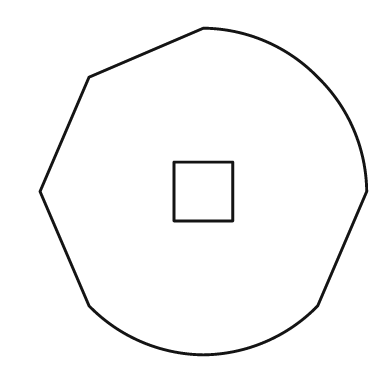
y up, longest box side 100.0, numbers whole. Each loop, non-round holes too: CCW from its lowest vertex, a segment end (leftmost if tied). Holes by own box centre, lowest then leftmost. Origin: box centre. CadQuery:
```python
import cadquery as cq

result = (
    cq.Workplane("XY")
    .moveTo(0.0, -50.0)
    .threePointArc((19.0, -46.0), (35.0, -35.0))
    .lineTo(50.0, 0.0)
    .threePointArc((46.0, 19.0), (35.0, 35.0))
    .threePointArc((19.0, 46.0), (0.0, 50.0))
    .lineTo(-35.0, 35.0)
    .lineTo(-50.0, 0.0)
    .lineTo(-35.0, -35.0)
    .threePointArc((-19.0, -46.0), (0.0, -50.0))
    .close()
    .moveTo(-9.0, -9.0)
    .lineTo(9.0, -9.0)
    .lineTo(9.0, 9.0)
    .lineTo(-9.0, 9.0)
    .close()
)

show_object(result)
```